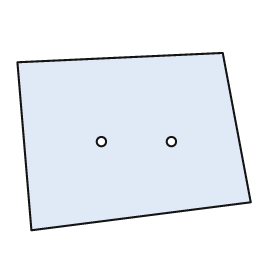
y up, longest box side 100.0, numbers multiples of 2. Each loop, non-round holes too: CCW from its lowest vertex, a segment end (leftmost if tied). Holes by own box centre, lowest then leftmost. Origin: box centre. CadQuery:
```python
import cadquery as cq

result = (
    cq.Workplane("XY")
    .moveTo(-44.0, -38.0)
    .lineTo(50.0, -26.0)
    .lineTo(38.0, 38.0)
    .lineTo(-50.0, 34.0)
    .close()
    .moveTo(-14.0, 0.0)
    .circle(2.0)
    .moveTo(16.0, 0.0)
    .circle(2.0)
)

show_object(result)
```